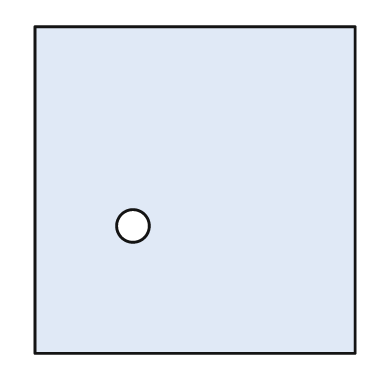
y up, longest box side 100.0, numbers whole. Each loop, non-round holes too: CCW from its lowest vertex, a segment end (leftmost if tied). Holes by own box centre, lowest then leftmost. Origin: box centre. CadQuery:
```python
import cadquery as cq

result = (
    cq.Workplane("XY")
    .moveTo(-49.0, -50.0)
    .lineTo(49.0, -50.0)
    .lineTo(49.0, 50.0)
    .lineTo(-49.0, 50.0)
    .close()
    .moveTo(-19.0, -11.0)
    .circle(5.0)
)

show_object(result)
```